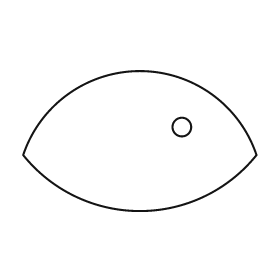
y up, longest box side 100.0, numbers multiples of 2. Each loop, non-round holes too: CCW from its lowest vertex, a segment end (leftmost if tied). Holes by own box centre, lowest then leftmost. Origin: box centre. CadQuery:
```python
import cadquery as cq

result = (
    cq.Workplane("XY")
    .moveTo(-50.0, -6.0)
    .threePointArc((0.0, -30.0), (50.0, -6.0))
    .threePointArc((0.0, 30.0), (-50.0, -6.0))
    .close()
    .moveTo(18.0, 6.0)
    .circle(4.0)
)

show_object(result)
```